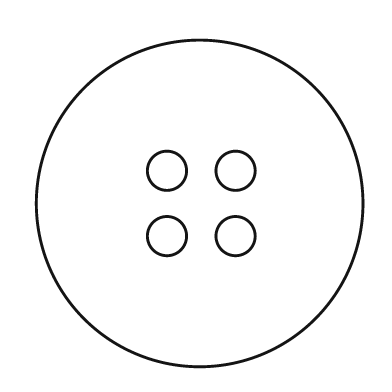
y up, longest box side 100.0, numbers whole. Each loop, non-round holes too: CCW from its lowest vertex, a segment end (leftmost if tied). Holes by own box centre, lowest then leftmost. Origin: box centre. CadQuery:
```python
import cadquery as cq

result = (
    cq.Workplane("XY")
    .moveTo(0.0, 0.0)
    .circle(50.0)
    .moveTo(-10.0, -10.0)
    .circle(6.0)
    .moveTo(11.0, -10.0)
    .circle(6.0)
    .moveTo(-10.0, 10.0)
    .circle(6.0)
    .moveTo(11.0, 10.0)
    .circle(6.0)
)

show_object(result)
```